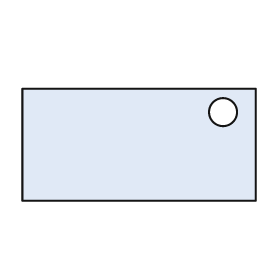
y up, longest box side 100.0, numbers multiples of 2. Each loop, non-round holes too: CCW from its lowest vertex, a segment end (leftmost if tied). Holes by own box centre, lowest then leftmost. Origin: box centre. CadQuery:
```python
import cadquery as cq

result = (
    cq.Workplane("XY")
    .moveTo(-50.0, -24.0)
    .lineTo(50.0, -24.0)
    .lineTo(50.0, 24.0)
    .lineTo(-50.0, 24.0)
    .close()
    .moveTo(36.0, 14.0)
    .circle(6.0)
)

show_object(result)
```